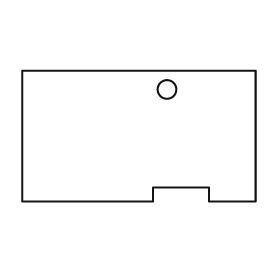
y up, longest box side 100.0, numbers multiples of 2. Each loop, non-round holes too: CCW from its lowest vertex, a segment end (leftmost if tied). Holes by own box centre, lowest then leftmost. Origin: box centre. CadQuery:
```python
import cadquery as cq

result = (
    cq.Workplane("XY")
    .moveTo(-50.0, -28.0)
    .lineTo(6.0, -28.0)
    .lineTo(6.0, -22.0)
    .lineTo(30.0, -22.0)
    .lineTo(30.0, -28.0)
    .lineTo(50.0, -28.0)
    .lineTo(50.0, 28.0)
    .lineTo(-50.0, 28.0)
    .close()
    .moveTo(12.0, 20.0)
    .circle(4.0)
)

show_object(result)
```